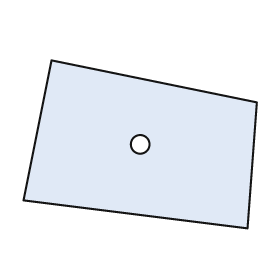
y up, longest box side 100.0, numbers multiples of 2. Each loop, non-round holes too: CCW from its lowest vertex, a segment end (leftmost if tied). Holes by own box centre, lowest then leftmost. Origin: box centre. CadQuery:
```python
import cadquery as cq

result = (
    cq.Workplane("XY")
    .moveTo(46.0, -36.0)
    .lineTo(50.0, 18.0)
    .lineTo(-38.0, 36.0)
    .lineTo(-50.0, -24.0)
    .close()
    .moveTo(0.0, 0.0)
    .circle(4.0)
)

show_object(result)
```